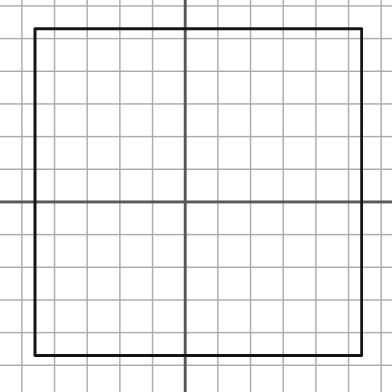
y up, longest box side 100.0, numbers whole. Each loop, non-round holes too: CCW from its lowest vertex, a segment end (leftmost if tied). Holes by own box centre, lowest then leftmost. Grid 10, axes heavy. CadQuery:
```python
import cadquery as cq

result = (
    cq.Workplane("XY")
    .moveTo(-46.0, -47.0)
    .lineTo(54.0, -47.0)
    .lineTo(54.0, 53.0)
    .lineTo(-46.0, 53.0)
    .close()
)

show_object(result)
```